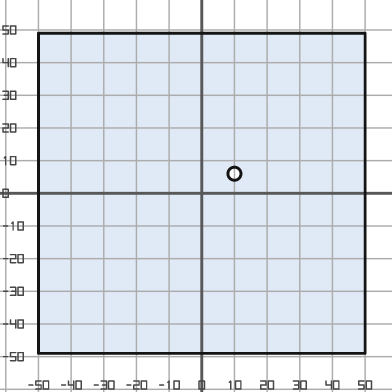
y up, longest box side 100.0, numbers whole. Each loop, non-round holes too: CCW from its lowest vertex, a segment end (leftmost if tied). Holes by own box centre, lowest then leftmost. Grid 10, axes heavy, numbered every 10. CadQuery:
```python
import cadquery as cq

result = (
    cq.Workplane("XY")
    .moveTo(-50.0, -49.0)
    .lineTo(50.0, -49.0)
    .lineTo(50.0, 49.0)
    .lineTo(-50.0, 49.0)
    .close()
    .moveTo(10.0, 6.0)
    .circle(2.0)
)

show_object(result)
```